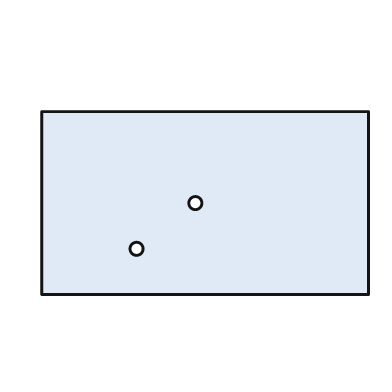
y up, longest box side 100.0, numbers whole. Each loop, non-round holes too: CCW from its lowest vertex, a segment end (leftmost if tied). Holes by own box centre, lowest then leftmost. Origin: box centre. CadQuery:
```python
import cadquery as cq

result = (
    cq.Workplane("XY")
    .moveTo(-50.0, -28.0)
    .lineTo(50.0, -28.0)
    .lineTo(50.0, 28.0)
    .lineTo(-50.0, 28.0)
    .close()
    .moveTo(-21.0, -14.0)
    .circle(2.0)
    .moveTo(-3.0, 0.0)
    .circle(2.0)
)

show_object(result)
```